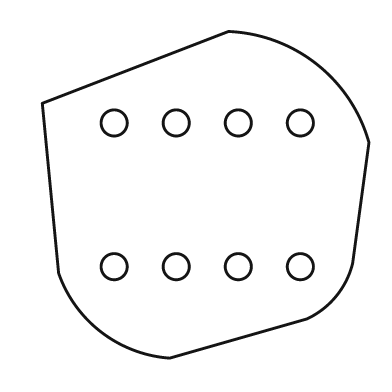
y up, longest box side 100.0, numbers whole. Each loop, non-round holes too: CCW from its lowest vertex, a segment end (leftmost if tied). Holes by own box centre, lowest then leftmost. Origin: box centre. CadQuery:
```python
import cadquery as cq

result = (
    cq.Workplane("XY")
    .moveTo(-11.0, -50.0)
    .lineTo(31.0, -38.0)
    .threePointArc((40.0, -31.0), (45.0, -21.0))
    .lineTo(50.0, 16.0)
    .threePointArc((34.0, 40.0), (7.0, 50.0))
    .lineTo(-50.0, 28.0)
    .lineTo(-45.0, -24.0)
    .threePointArc((-32.0, -42.0), (-11.0, -50.0))
    .close()
    .moveTo(-28.0, -22.0)
    .circle(4.0)
    .moveTo(-9.0, -22.0)
    .circle(4.0)
    .moveTo(10.0, -22.0)
    .circle(4.0)
    .moveTo(29.0, -22.0)
    .circle(4.0)
    .moveTo(-28.0, 22.0)
    .circle(4.0)
    .moveTo(-9.0, 22.0)
    .circle(4.0)
    .moveTo(10.0, 22.0)
    .circle(4.0)
    .moveTo(29.0, 22.0)
    .circle(4.0)
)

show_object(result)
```